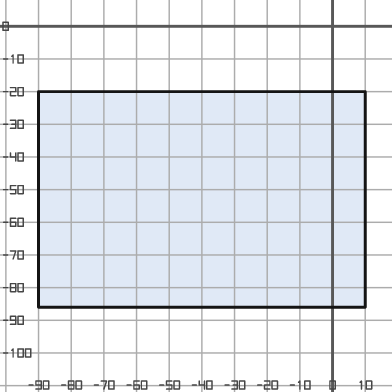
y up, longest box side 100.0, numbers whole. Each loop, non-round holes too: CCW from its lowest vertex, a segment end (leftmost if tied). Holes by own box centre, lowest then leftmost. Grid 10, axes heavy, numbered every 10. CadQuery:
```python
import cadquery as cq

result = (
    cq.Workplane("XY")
    .moveTo(-90.0, -86.0)
    .lineTo(10.0, -86.0)
    .lineTo(10.0, -20.0)
    .lineTo(-90.0, -20.0)
    .close()
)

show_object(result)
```